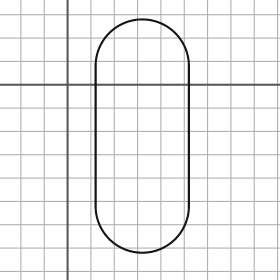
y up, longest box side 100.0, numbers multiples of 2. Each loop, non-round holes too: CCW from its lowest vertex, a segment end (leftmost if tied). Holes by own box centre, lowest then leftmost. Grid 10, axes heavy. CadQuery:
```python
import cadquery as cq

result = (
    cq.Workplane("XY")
    .moveTo(12.0, -52.0)
    .threePointArc((32.0, -72.0), (52.0, -52.0))
    .lineTo(52.0, 8.0)
    .threePointArc((32.0, 28.0), (12.0, 8.0))
    .close()
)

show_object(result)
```